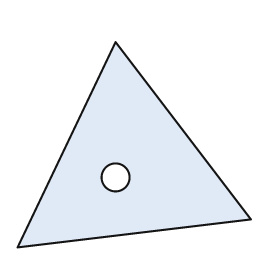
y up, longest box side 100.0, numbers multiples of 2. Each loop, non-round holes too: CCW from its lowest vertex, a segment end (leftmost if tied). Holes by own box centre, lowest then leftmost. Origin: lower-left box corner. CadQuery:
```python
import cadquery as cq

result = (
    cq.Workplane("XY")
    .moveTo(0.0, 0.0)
    .lineTo(100.0, 12.0)
    .lineTo(42.0, 88.0)
    .close()
    .moveTo(42.0, 30.0)
    .circle(6.0)
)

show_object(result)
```